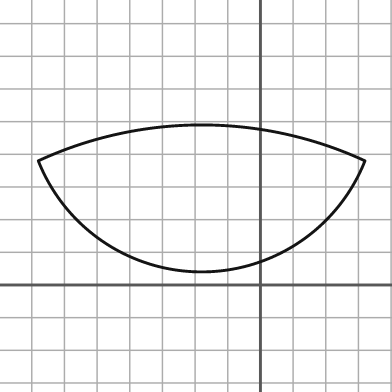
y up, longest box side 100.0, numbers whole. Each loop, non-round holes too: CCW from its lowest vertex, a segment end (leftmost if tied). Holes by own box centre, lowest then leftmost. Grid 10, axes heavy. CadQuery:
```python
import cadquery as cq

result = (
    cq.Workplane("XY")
    .moveTo(-68.0, 38.0)
    .threePointArc((-18.0, 4.0), (32.0, 38.0))
    .threePointArc((-18.0, 49.0), (-68.0, 38.0))
    .close()
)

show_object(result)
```